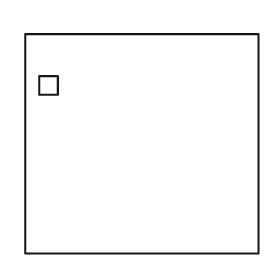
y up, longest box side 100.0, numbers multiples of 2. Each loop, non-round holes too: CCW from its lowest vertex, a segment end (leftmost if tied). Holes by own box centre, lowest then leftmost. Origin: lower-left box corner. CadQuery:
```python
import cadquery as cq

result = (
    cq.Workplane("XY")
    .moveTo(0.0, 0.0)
    .lineTo(100.0, 0.0)
    .lineTo(100.0, 94.0)
    .lineTo(0.0, 94.0)
    .close()
    .moveTo(6.0, 68.0)
    .lineTo(14.0, 68.0)
    .lineTo(14.0, 76.0)
    .lineTo(6.0, 76.0)
    .close()
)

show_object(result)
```